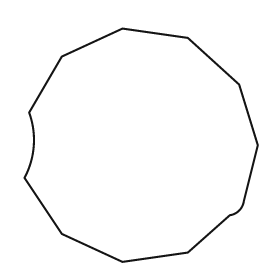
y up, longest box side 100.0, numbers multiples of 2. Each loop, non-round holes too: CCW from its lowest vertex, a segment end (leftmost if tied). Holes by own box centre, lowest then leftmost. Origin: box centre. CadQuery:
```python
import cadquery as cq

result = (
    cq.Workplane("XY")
    .moveTo(-8.0, -50.0)
    .lineTo(20.0, -46.0)
    .lineTo(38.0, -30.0)
    .threePointArc((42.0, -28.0), (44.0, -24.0))
    .lineTo(50.0, 0.0)
    .lineTo(42.0, 26.0)
    .lineTo(20.0, 46.0)
    .lineTo(-8.0, 50.0)
    .lineTo(-34.0, 38.0)
    .lineTo(-48.0, 14.0)
    .threePointArc((-46.0, 0.0), (-50.0, -14.0))
    .lineTo(-34.0, -38.0)
    .close()
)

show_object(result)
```